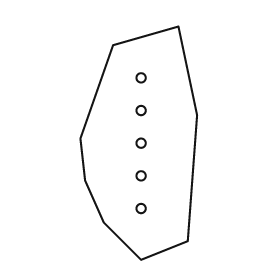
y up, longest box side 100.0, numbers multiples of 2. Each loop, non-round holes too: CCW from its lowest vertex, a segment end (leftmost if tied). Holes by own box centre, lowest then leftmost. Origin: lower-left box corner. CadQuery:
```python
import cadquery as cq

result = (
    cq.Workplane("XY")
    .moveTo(26.0, 0.0)
    .lineTo(46.0, 8.0)
    .lineTo(50.0, 62.0)
    .lineTo(42.0, 100.0)
    .lineTo(14.0, 92.0)
    .lineTo(0.0, 52.0)
    .lineTo(2.0, 34.0)
    .lineTo(10.0, 16.0)
    .close()
    .moveTo(26.0, 22.0)
    .circle(2.0)
    .moveTo(26.0, 36.0)
    .circle(2.0)
    .moveTo(26.0, 50.0)
    .circle(2.0)
    .moveTo(26.0, 64.0)
    .circle(2.0)
    .moveTo(26.0, 78.0)
    .circle(2.0)
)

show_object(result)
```